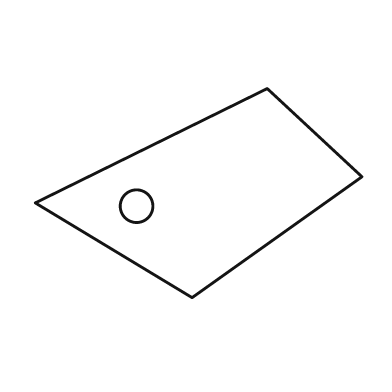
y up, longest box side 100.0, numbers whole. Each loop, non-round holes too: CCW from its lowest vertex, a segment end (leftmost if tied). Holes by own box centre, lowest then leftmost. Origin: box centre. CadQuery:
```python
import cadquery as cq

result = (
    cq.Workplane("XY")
    .moveTo(-2.0, -32.0)
    .lineTo(50.0, 5.0)
    .lineTo(21.0, 32.0)
    .lineTo(-50.0, -3.0)
    .close()
    .moveTo(-19.0, -4.0)
    .circle(5.0)
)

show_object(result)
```